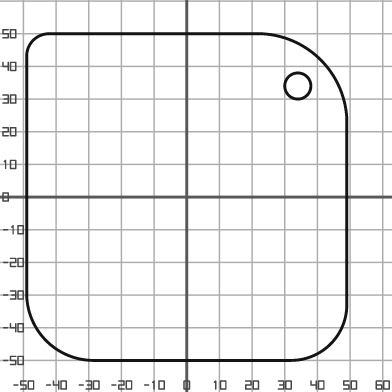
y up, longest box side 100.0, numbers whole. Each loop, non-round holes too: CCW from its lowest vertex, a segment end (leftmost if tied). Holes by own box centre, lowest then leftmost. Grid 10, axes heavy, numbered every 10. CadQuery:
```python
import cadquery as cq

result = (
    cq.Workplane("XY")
    .moveTo(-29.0, -50.0)
    .lineTo(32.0, -50.0)
    .threePointArc((44.0, -45.0), (49.0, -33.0))
    .lineTo(49.0, 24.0)
    .threePointArc((41.0, 42.0), (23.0, 50.0))
    .lineTo(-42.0, 50.0)
    .threePointArc((-47.0, 48.0), (-49.0, 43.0))
    .lineTo(-49.0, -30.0)
    .threePointArc((-43.0, -44.0), (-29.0, -50.0))
    .close()
    .moveTo(34.0, 34.0)
    .circle(4.0)
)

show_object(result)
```